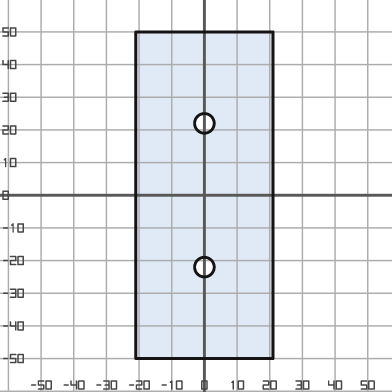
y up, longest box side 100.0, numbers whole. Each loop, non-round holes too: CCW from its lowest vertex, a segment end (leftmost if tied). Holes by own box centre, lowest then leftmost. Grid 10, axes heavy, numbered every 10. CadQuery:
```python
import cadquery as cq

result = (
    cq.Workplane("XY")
    .moveTo(-21.0, -50.0)
    .lineTo(21.0, -50.0)
    .lineTo(21.0, 50.0)
    .lineTo(-21.0, 50.0)
    .close()
    .moveTo(0.0, -22.0)
    .circle(3.0)
    .moveTo(0.0, 22.0)
    .circle(3.0)
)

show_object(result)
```